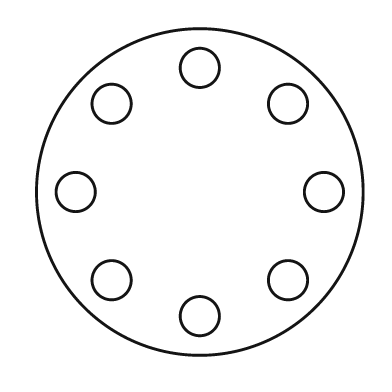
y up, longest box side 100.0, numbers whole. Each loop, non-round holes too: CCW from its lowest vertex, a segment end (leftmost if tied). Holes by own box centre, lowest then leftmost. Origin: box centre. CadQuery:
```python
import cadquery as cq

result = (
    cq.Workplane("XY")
    .moveTo(0.0, 0.0)
    .circle(50.0)
    .moveTo(0.0, -38.0)
    .circle(6.0)
    .moveTo(-27.0, -27.0)
    .circle(6.0)
    .moveTo(27.0, -27.0)
    .circle(6.0)
    .moveTo(-38.0, 0.0)
    .circle(6.0)
    .moveTo(38.0, 0.0)
    .circle(6.0)
    .moveTo(-27.0, 27.0)
    .circle(6.0)
    .moveTo(27.0, 27.0)
    .circle(6.0)
    .moveTo(0.0, 38.0)
    .circle(6.0)
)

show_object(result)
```